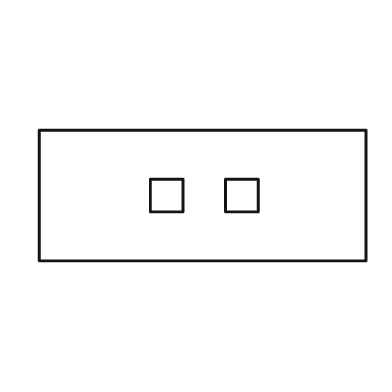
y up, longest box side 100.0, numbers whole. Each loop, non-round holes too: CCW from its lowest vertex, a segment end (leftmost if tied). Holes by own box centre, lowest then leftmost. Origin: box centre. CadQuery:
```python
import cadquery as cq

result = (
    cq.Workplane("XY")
    .moveTo(-50.0, -20.0)
    .lineTo(50.0, -20.0)
    .lineTo(50.0, 20.0)
    .lineTo(-50.0, 20.0)
    .close()
    .moveTo(-16.0, -5.0)
    .lineTo(-6.0, -5.0)
    .lineTo(-6.0, 5.0)
    .lineTo(-16.0, 5.0)
    .close()
    .moveTo(7.0, -5.0)
    .lineTo(17.0, -5.0)
    .lineTo(17.0, 5.0)
    .lineTo(7.0, 5.0)
    .close()
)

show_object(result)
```